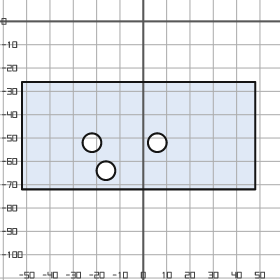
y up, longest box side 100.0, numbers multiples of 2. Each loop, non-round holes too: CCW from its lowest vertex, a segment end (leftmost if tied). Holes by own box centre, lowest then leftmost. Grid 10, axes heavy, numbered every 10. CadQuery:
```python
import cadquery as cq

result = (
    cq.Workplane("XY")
    .moveTo(-52.0, -72.0)
    .lineTo(48.0, -72.0)
    .lineTo(48.0, -26.0)
    .lineTo(-52.0, -26.0)
    .close()
    .moveTo(-16.0, -64.0)
    .circle(4.0)
    .moveTo(-22.0, -52.0)
    .circle(4.0)
    .moveTo(6.0, -52.0)
    .circle(4.0)
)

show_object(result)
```